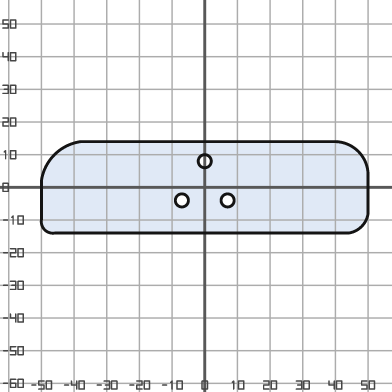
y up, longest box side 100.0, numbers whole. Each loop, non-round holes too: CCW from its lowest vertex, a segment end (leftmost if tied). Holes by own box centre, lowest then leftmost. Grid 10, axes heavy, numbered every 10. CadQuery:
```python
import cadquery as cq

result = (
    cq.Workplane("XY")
    .moveTo(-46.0, -14.0)
    .lineTo(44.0, -14.0)
    .threePointArc((48.0, -12.0), (50.0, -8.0))
    .lineTo(50.0, 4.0)
    .threePointArc((47.0, 11.0), (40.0, 14.0))
    .lineTo(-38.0, 14.0)
    .threePointArc((-46.0, 10.0), (-50.0, 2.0))
    .lineTo(-50.0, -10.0)
    .threePointArc((-49.0, -13.0), (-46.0, -14.0))
    .close()
    .moveTo(-7.0, -4.0)
    .circle(2.0)
    .moveTo(7.0, -4.0)
    .circle(2.0)
    .moveTo(0.0, 8.0)
    .circle(2.0)
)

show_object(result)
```